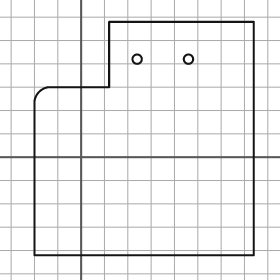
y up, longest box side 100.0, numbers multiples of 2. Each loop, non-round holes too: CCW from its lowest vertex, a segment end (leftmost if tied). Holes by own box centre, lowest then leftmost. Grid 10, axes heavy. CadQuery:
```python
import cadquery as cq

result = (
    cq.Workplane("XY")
    .moveTo(-20.0, -42.0)
    .lineTo(74.0, -42.0)
    .lineTo(74.0, 58.0)
    .lineTo(12.0, 58.0)
    .lineTo(12.0, 30.0)
    .lineTo(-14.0, 30.0)
    .threePointArc((-18.0, 28.0), (-20.0, 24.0))
    .close()
    .moveTo(24.0, 42.0)
    .circle(2.0)
    .moveTo(46.0, 42.0)
    .circle(2.0)
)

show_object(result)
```